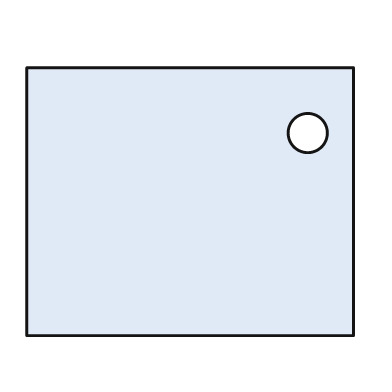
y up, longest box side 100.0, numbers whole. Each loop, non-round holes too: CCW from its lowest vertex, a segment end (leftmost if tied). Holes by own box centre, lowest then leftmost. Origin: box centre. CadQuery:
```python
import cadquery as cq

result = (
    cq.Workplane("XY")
    .moveTo(-50.0, -41.0)
    .lineTo(50.0, -41.0)
    .lineTo(50.0, 41.0)
    .lineTo(-50.0, 41.0)
    .close()
    .moveTo(36.0, 21.0)
    .circle(6.0)
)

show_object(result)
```